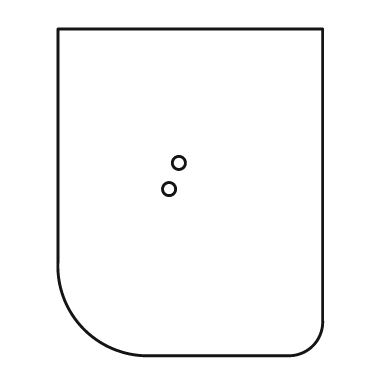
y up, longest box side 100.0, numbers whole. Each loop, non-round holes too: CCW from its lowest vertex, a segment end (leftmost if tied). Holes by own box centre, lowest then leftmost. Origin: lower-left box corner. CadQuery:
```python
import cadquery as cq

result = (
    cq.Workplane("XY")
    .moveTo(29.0, 0.0)
    .lineTo(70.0, 0.0)
    .threePointArc((78.0, 3.0), (81.0, 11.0))
    .lineTo(81.0, 100.0)
    .lineTo(0.0, 100.0)
    .lineTo(0.0, 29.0)
    .threePointArc((8.0, 8.0), (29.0, 0.0))
    .close()
    .moveTo(34.0, 51.0)
    .circle(2.0)
    .moveTo(37.0, 59.0)
    .circle(2.0)
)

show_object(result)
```